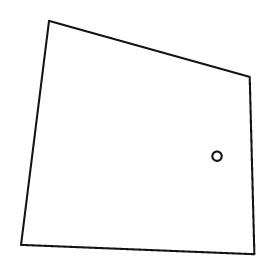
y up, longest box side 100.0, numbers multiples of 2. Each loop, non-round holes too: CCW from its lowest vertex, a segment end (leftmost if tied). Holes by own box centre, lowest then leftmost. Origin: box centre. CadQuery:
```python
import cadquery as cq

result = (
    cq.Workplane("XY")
    .moveTo(50.0, -50.0)
    .lineTo(48.0, 26.0)
    .lineTo(-38.0, 50.0)
    .lineTo(-50.0, -46.0)
    .close()
    .moveTo(34.0, -8.0)
    .circle(2.0)
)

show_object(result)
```